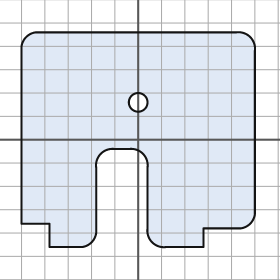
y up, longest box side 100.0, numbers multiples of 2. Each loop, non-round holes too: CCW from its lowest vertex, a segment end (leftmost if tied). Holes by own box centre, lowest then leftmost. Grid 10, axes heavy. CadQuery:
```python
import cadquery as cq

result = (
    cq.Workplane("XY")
    .moveTo(-38.0, -46.0)
    .lineTo(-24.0, -46.0)
    .threePointArc((-20.0, -44.0), (-18.0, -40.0))
    .lineTo(-18.0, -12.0)
    .threePointArc((-16.0, -6.0), (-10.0, -4.0))
    .lineTo(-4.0, -4.0)
    .threePointArc((2.0, -6.0), (4.0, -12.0))
    .lineTo(4.0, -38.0)
    .threePointArc((6.0, -44.0), (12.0, -46.0))
    .lineTo(28.0, -46.0)
    .lineTo(28.0, -38.0)
    .lineTo(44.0, -38.0)
    .threePointArc((48.0, -36.0), (50.0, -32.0))
    .lineTo(50.0, 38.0)
    .threePointArc((48.0, 44.0), (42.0, 46.0))
    .lineTo(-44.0, 46.0)
    .threePointArc((-48.0, 44.0), (-50.0, 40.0))
    .lineTo(-50.0, -36.0)
    .lineTo(-38.0, -36.0)
    .close()
    .moveTo(0.0, 16.0)
    .circle(4.0)
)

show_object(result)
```